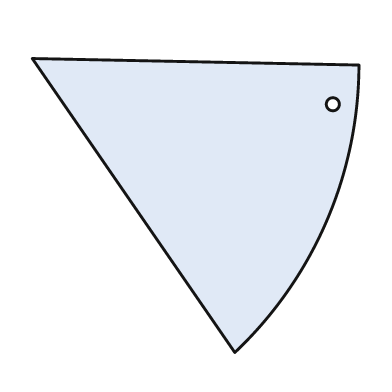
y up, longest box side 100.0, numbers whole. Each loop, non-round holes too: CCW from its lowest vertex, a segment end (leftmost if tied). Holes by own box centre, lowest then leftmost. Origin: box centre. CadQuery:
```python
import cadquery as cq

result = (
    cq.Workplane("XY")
    .moveTo(12.0, -45.0)
    .threePointArc((40.0, -5.0), (50.0, 43.0))
    .lineTo(-50.0, 45.0)
    .close()
    .moveTo(42.0, 31.0)
    .circle(2.0)
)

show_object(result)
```